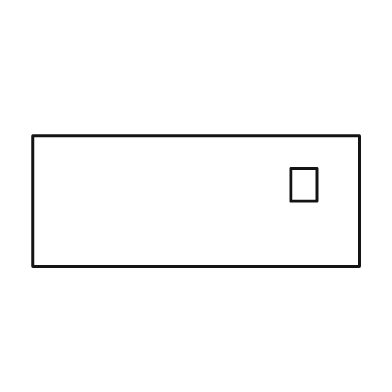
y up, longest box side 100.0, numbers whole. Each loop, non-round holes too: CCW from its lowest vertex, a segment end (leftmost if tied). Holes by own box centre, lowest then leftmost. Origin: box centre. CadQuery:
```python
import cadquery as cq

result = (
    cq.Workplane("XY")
    .moveTo(-50.0, -20.0)
    .lineTo(50.0, -20.0)
    .lineTo(50.0, 20.0)
    .lineTo(-50.0, 20.0)
    .close()
    .moveTo(29.0, 0.0)
    .lineTo(37.0, 0.0)
    .lineTo(37.0, 10.0)
    .lineTo(29.0, 10.0)
    .close()
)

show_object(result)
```